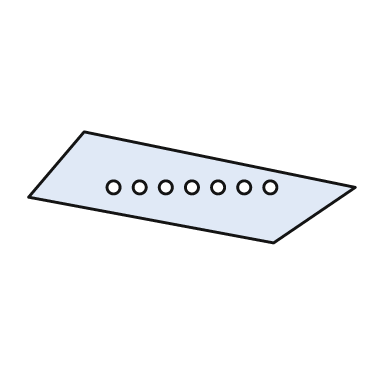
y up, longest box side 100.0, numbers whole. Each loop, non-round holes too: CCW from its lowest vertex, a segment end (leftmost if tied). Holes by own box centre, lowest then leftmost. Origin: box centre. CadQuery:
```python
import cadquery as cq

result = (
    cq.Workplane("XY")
    .moveTo(25.0, -17.0)
    .lineTo(50.0, 0.0)
    .lineTo(-33.0, 17.0)
    .lineTo(-50.0, -3.0)
    .close()
    .moveTo(-24.0, 0.0)
    .circle(2.0)
    .moveTo(-16.0, 0.0)
    .circle(2.0)
    .moveTo(-8.0, 0.0)
    .circle(2.0)
    .moveTo(0.0, 0.0)
    .circle(2.0)
    .moveTo(8.0, 0.0)
    .circle(2.0)
    .moveTo(16.0, 0.0)
    .circle(2.0)
    .moveTo(24.0, 0.0)
    .circle(2.0)
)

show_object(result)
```